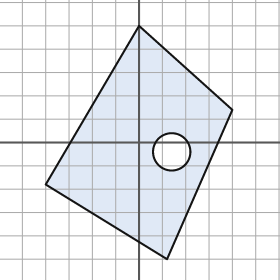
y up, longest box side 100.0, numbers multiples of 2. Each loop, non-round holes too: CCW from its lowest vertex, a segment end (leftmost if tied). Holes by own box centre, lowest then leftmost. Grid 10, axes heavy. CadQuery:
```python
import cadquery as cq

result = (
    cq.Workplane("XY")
    .moveTo(12.0, -50.0)
    .lineTo(40.0, 14.0)
    .lineTo(0.0, 50.0)
    .lineTo(-40.0, -18.0)
    .close()
    .moveTo(14.0, -4.0)
    .circle(8.0)
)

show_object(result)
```